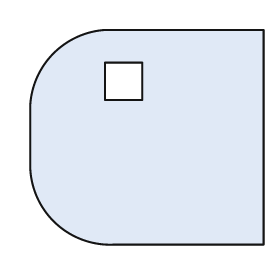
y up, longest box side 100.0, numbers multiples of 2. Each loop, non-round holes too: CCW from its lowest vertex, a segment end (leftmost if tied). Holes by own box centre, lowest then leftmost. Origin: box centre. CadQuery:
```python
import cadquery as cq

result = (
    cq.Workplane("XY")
    .moveTo(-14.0, -46.0)
    .lineTo(50.0, -46.0)
    .lineTo(50.0, 46.0)
    .lineTo(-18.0, 46.0)
    .threePointArc((-40.0, 36.0), (-50.0, 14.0))
    .lineTo(-50.0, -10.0)
    .threePointArc((-40.0, -36.0), (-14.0, -46.0))
    .close()
    .moveTo(-18.0, 16.0)
    .lineTo(-2.0, 16.0)
    .lineTo(-2.0, 32.0)
    .lineTo(-18.0, 32.0)
    .close()
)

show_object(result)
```